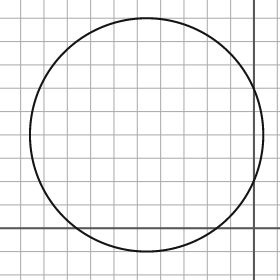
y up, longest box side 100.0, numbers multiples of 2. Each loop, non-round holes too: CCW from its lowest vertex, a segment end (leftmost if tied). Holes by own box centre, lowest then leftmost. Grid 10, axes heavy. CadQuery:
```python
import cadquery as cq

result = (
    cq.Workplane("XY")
    .moveTo(-46.0, 40.0)
    .circle(50.0)
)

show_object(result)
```